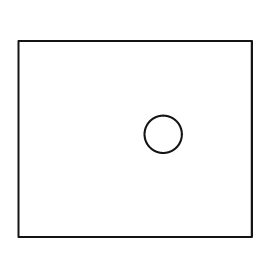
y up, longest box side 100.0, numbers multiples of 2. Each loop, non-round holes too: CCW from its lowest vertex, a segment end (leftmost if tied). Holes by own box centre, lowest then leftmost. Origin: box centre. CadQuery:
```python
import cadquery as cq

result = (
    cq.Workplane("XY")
    .moveTo(-50.0, -42.0)
    .lineTo(50.0, -42.0)
    .lineTo(50.0, 42.0)
    .lineTo(-50.0, 42.0)
    .close()
    .moveTo(12.0, 2.0)
    .circle(8.0)
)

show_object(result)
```